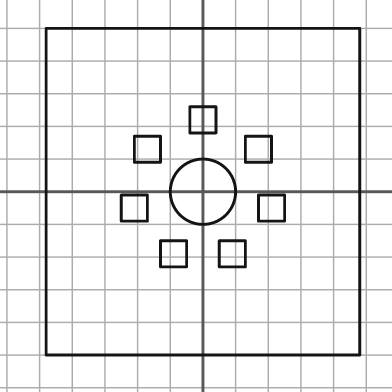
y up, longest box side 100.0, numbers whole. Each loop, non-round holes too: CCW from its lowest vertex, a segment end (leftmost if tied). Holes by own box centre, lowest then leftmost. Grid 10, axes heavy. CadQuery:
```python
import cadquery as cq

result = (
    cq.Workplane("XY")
    .moveTo(-48.0, -50.0)
    .lineTo(48.0, -50.0)
    .lineTo(48.0, 50.0)
    .lineTo(-48.0, 50.0)
    .close()
    .moveTo(-13.0, -23.0)
    .lineTo(-5.0, -23.0)
    .lineTo(-5.0, -15.0)
    .lineTo(-13.0, -15.0)
    .close()
    .moveTo(5.0, -23.0)
    .lineTo(13.0, -23.0)
    .lineTo(13.0, -15.0)
    .lineTo(5.0, -15.0)
    .close()
    .moveTo(-25.0, -9.0)
    .lineTo(-17.0, -9.0)
    .lineTo(-17.0, -1.0)
    .lineTo(-25.0, -1.0)
    .close()
    .moveTo(17.0, -9.0)
    .lineTo(25.0, -9.0)
    .lineTo(25.0, -1.0)
    .lineTo(17.0, -1.0)
    .close()
    .moveTo(0.0, 0.0)
    .circle(10.0)
    .moveTo(-21.0, 9.0)
    .lineTo(-13.0, 9.0)
    .lineTo(-13.0, 17.0)
    .lineTo(-21.0, 17.0)
    .close()
    .moveTo(13.0, 9.0)
    .lineTo(21.0, 9.0)
    .lineTo(21.0, 17.0)
    .lineTo(13.0, 17.0)
    .close()
    .moveTo(-4.0, 18.0)
    .lineTo(4.0, 18.0)
    .lineTo(4.0, 26.0)
    .lineTo(-4.0, 26.0)
    .close()
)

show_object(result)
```